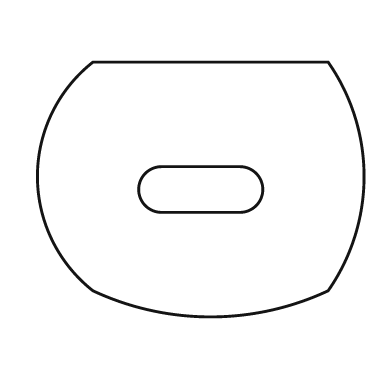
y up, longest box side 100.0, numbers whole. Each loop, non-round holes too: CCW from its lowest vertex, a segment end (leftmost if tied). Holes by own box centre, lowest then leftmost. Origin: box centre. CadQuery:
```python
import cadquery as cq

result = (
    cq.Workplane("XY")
    .moveTo(-33.0, -31.0)
    .threePointArc((3.0, -39.0), (39.0, -31.0))
    .threePointArc((50.0, 4.0), (39.0, 39.0))
    .lineTo(-33.0, 39.0)
    .threePointArc((-50.0, 4.0), (-33.0, -31.0))
    .close()
    .moveTo(-12.0, -7.0)
    .lineTo(12.0, -7.0)
    .threePointArc((19.0, 0.0), (12.0, 7.0))
    .lineTo(-12.0, 7.0)
    .threePointArc((-19.0, 0.0), (-12.0, -7.0))
    .close()
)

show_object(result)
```